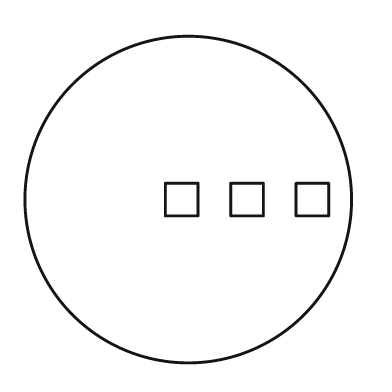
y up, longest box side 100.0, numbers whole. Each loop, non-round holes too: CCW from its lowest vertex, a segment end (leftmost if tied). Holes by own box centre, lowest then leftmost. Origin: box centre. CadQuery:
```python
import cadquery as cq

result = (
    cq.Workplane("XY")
    .moveTo(0.0, 0.0)
    .circle(50.0)
    .moveTo(-7.0, -5.0)
    .lineTo(3.0, -5.0)
    .lineTo(3.0, 5.0)
    .lineTo(-7.0, 5.0)
    .close()
    .moveTo(13.0, -5.0)
    .lineTo(23.0, -5.0)
    .lineTo(23.0, 5.0)
    .lineTo(13.0, 5.0)
    .close()
    .moveTo(33.0, -5.0)
    .lineTo(43.0, -5.0)
    .lineTo(43.0, 5.0)
    .lineTo(33.0, 5.0)
    .close()
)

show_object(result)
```